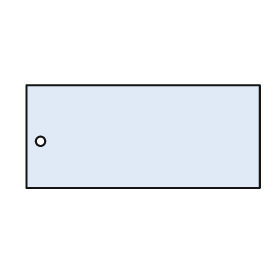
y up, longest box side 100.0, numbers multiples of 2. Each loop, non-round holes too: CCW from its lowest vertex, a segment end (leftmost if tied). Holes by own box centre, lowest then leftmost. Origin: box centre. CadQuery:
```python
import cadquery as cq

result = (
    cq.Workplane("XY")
    .moveTo(-50.0, -22.0)
    .lineTo(50.0, -22.0)
    .lineTo(50.0, 22.0)
    .lineTo(-50.0, 22.0)
    .close()
    .moveTo(-44.0, -2.0)
    .circle(2.0)
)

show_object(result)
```